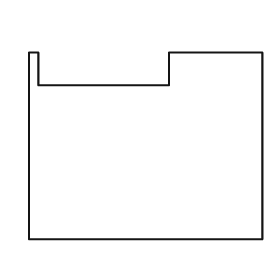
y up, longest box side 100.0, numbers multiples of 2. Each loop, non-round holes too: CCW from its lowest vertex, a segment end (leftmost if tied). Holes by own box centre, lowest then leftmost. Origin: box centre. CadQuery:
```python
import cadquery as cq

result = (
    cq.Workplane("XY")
    .moveTo(-50.0, -40.0)
    .lineTo(50.0, -40.0)
    .lineTo(50.0, 40.0)
    .lineTo(10.0, 40.0)
    .lineTo(10.0, 26.0)
    .lineTo(-46.0, 26.0)
    .lineTo(-46.0, 40.0)
    .lineTo(-50.0, 40.0)
    .close()
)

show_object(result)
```